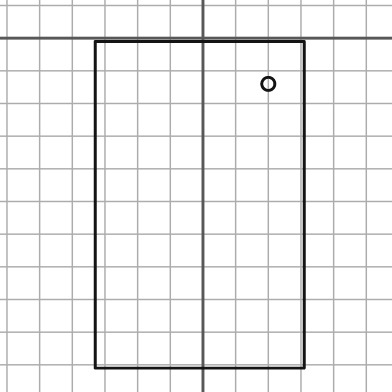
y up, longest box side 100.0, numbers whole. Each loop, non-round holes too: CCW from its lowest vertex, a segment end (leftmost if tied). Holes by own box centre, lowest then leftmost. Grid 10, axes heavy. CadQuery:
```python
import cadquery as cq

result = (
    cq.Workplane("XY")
    .moveTo(-33.0, -101.0)
    .lineTo(31.0, -101.0)
    .lineTo(31.0, -1.0)
    .lineTo(-33.0, -1.0)
    .close()
    .moveTo(20.0, -14.0)
    .circle(2.0)
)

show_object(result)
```